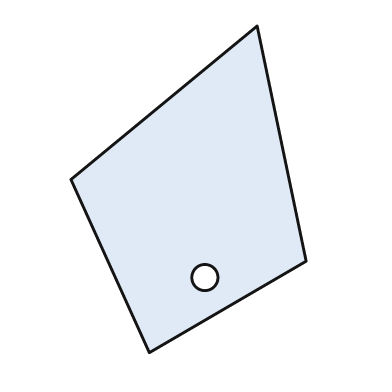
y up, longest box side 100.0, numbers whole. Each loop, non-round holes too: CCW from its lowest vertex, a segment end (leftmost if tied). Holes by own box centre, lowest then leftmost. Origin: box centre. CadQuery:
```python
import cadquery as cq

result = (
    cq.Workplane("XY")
    .moveTo(-12.0, -50.0)
    .lineTo(36.0, -22.0)
    .lineTo(21.0, 50.0)
    .lineTo(-36.0, 3.0)
    .close()
    .moveTo(5.0, -27.0)
    .circle(4.0)
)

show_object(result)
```